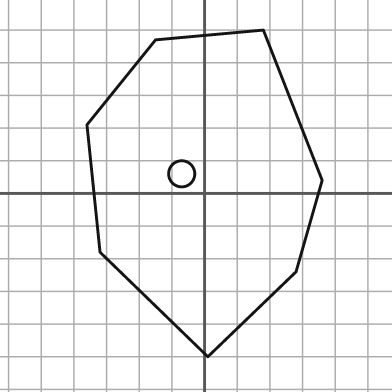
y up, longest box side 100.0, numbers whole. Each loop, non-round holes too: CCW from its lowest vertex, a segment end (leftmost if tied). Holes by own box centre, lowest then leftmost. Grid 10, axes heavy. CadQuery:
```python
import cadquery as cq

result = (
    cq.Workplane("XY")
    .moveTo(1.0, -50.0)
    .lineTo(28.0, -24.0)
    .lineTo(36.0, 4.0)
    .lineTo(18.0, 50.0)
    .lineTo(-15.0, 47.0)
    .lineTo(-36.0, 21.0)
    .lineTo(-32.0, -18.0)
    .close()
    .moveTo(-7.0, 6.0)
    .circle(4.0)
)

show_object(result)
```